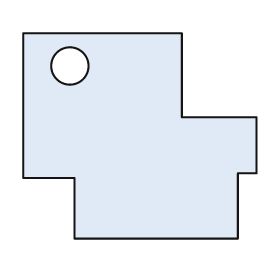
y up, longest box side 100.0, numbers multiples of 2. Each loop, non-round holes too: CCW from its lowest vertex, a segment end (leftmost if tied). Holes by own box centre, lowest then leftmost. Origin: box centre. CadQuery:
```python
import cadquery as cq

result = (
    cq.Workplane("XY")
    .moveTo(-28.0, -44.0)
    .lineTo(42.0, -44.0)
    .lineTo(42.0, -16.0)
    .lineTo(50.0, -16.0)
    .lineTo(50.0, 8.0)
    .lineTo(18.0, 8.0)
    .lineTo(18.0, 44.0)
    .lineTo(-50.0, 44.0)
    .lineTo(-50.0, -18.0)
    .lineTo(-28.0, -18.0)
    .close()
    .moveTo(-30.0, 30.0)
    .circle(8.0)
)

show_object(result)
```